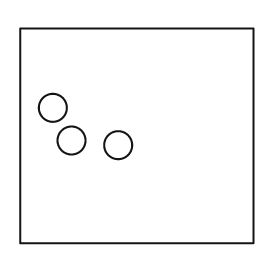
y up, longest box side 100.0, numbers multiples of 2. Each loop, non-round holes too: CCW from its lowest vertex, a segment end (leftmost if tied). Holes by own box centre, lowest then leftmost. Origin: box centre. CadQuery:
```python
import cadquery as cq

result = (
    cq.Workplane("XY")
    .moveTo(-50.0, -46.0)
    .lineTo(50.0, -46.0)
    .lineTo(50.0, 46.0)
    .lineTo(-50.0, 46.0)
    .close()
    .moveTo(-8.0, -4.0)
    .circle(6.0)
    .moveTo(-28.0, -2.0)
    .circle(6.0)
    .moveTo(-36.0, 12.0)
    .circle(6.0)
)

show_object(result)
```